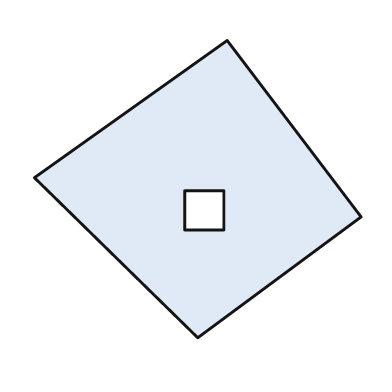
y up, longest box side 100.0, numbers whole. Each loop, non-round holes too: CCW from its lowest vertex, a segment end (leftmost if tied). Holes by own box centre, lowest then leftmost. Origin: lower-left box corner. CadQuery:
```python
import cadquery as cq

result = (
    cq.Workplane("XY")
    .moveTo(50.0, 0.0)
    .lineTo(100.0, 37.0)
    .lineTo(59.0, 91.0)
    .lineTo(0.0, 49.0)
    .close()
    .moveTo(46.0, 33.0)
    .lineTo(58.0, 33.0)
    .lineTo(58.0, 45.0)
    .lineTo(46.0, 45.0)
    .close()
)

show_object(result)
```